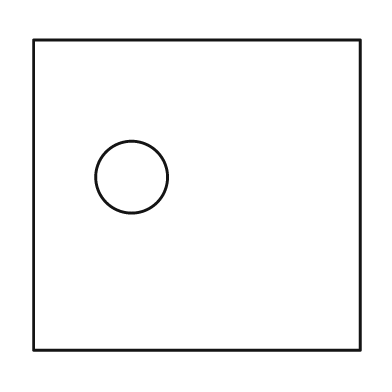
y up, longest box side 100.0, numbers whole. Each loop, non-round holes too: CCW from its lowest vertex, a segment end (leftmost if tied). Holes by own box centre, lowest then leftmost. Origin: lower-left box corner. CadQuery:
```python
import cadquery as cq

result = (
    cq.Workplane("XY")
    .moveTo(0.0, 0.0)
    .lineTo(100.0, 0.0)
    .lineTo(100.0, 95.0)
    .lineTo(0.0, 95.0)
    .close()
    .moveTo(30.0, 53.0)
    .circle(11.0)
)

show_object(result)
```